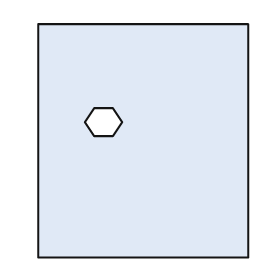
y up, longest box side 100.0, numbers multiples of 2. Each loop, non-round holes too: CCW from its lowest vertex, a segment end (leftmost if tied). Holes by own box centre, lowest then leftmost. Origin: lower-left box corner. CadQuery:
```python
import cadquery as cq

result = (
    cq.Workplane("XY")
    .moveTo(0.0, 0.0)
    .lineTo(90.0, 0.0)
    .lineTo(90.0, 100.0)
    .lineTo(0.0, 100.0)
    .close()
    .moveTo(24.0, 52.0)
    .lineTo(32.0, 52.0)
    .lineTo(36.0, 58.0)
    .lineTo(32.0, 64.0)
    .lineTo(24.0, 64.0)
    .lineTo(20.0, 58.0)
    .close()
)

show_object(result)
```